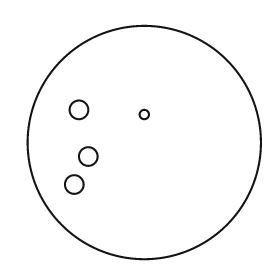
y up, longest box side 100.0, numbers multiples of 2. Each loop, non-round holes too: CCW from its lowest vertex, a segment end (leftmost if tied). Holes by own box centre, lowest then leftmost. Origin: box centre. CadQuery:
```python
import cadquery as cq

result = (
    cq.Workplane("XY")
    .moveTo(0.0, 0.0)
    .circle(50.0)
    .moveTo(-30.0, -18.0)
    .circle(4.0)
    .moveTo(-24.0, -6.0)
    .circle(4.0)
    .moveTo(0.0, 12.0)
    .circle(2.0)
    .moveTo(-28.0, 14.0)
    .circle(4.0)
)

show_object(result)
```